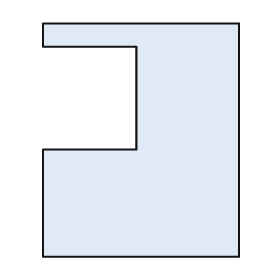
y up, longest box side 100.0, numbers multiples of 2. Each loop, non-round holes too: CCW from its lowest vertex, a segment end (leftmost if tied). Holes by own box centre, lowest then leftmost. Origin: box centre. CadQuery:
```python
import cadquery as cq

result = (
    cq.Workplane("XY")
    .moveTo(-42.0, -50.0)
    .lineTo(42.0, -50.0)
    .lineTo(42.0, 50.0)
    .lineTo(-42.0, 50.0)
    .lineTo(-42.0, 40.0)
    .lineTo(-2.0, 40.0)
    .lineTo(-2.0, -4.0)
    .lineTo(-42.0, -4.0)
    .close()
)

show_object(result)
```